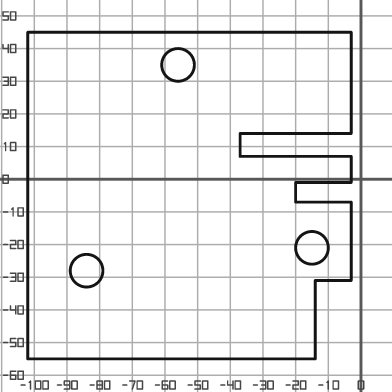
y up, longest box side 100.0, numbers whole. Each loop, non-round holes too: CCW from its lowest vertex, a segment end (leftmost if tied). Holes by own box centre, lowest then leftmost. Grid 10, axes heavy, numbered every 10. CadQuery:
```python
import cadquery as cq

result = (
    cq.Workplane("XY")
    .moveTo(-102.0, -55.0)
    .lineTo(-14.0, -55.0)
    .lineTo(-14.0, -31.0)
    .lineTo(-3.0, -31.0)
    .lineTo(-3.0, -7.0)
    .lineTo(-20.0, -7.0)
    .lineTo(-20.0, -1.0)
    .lineTo(-3.0, -1.0)
    .lineTo(-3.0, 7.0)
    .lineTo(-37.0, 7.0)
    .lineTo(-37.0, 14.0)
    .lineTo(-3.0, 14.0)
    .lineTo(-3.0, 45.0)
    .lineTo(-102.0, 45.0)
    .close()
    .moveTo(-84.0, -28.0)
    .circle(5.0)
    .moveTo(-15.0, -21.0)
    .circle(5.0)
    .moveTo(-56.0, 35.0)
    .circle(5.0)
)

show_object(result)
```